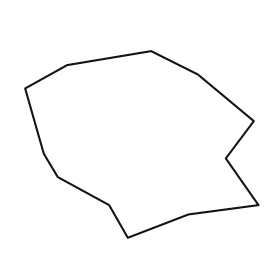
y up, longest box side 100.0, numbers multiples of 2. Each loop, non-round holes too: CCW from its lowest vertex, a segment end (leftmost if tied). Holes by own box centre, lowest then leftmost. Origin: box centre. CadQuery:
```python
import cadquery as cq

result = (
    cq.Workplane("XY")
    .moveTo(-6.0, -40.0)
    .lineTo(20.0, -30.0)
    .lineTo(50.0, -26.0)
    .lineTo(36.0, -6.0)
    .lineTo(48.0, 10.0)
    .lineTo(24.0, 30.0)
    .lineTo(4.0, 40.0)
    .lineTo(-32.0, 34.0)
    .lineTo(-50.0, 24.0)
    .lineTo(-42.0, -4.0)
    .lineTo(-36.0, -14.0)
    .lineTo(-14.0, -26.0)
    .close()
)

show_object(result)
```